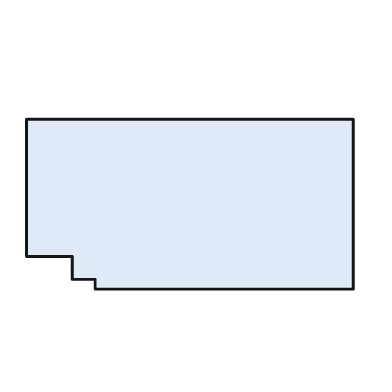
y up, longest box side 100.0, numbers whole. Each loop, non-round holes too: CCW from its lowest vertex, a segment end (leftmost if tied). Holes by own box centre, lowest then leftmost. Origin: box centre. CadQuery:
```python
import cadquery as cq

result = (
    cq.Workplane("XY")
    .moveTo(-29.0, -26.0)
    .lineTo(50.0, -26.0)
    .lineTo(50.0, 26.0)
    .lineTo(-50.0, 26.0)
    .lineTo(-50.0, -16.0)
    .lineTo(-36.0, -16.0)
    .lineTo(-36.0, -23.0)
    .lineTo(-29.0, -23.0)
    .close()
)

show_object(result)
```